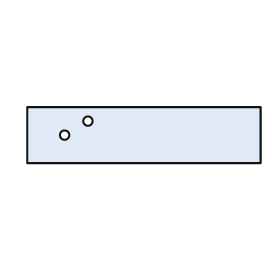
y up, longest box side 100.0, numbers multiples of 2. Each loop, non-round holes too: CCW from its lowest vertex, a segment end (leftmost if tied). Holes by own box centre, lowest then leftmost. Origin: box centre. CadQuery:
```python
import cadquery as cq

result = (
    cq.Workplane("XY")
    .moveTo(-50.0, -12.0)
    .lineTo(50.0, -12.0)
    .lineTo(50.0, 12.0)
    .lineTo(-50.0, 12.0)
    .close()
    .moveTo(-34.0, 0.0)
    .circle(2.0)
    .moveTo(-24.0, 6.0)
    .circle(2.0)
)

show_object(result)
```